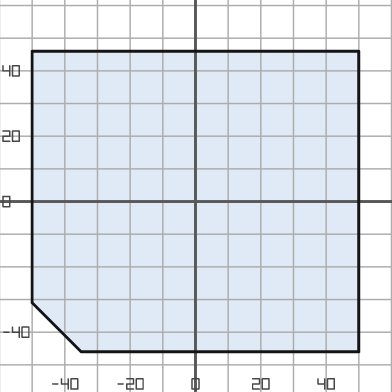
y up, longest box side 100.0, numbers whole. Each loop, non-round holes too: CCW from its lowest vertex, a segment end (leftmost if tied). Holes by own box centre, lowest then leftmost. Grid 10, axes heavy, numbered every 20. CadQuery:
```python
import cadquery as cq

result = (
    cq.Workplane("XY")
    .moveTo(-35.0, -46.0)
    .lineTo(50.0, -46.0)
    .lineTo(50.0, 46.0)
    .lineTo(-50.0, 46.0)
    .lineTo(-50.0, -31.0)
    .close()
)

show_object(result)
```